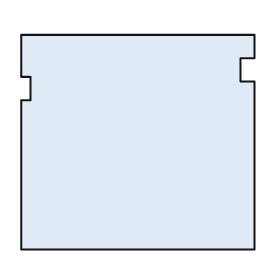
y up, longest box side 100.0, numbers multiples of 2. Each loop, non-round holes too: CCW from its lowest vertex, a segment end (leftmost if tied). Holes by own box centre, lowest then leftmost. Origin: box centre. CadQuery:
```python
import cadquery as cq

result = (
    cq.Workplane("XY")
    .moveTo(-50.0, -46.0)
    .lineTo(50.0, -46.0)
    .lineTo(50.0, 26.0)
    .lineTo(44.0, 26.0)
    .lineTo(44.0, 36.0)
    .lineTo(50.0, 36.0)
    .lineTo(50.0, 46.0)
    .lineTo(-50.0, 46.0)
    .lineTo(-50.0, 28.0)
    .lineTo(-46.0, 28.0)
    .lineTo(-46.0, 18.0)
    .lineTo(-50.0, 18.0)
    .close()
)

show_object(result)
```